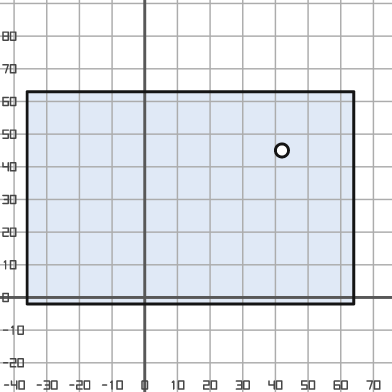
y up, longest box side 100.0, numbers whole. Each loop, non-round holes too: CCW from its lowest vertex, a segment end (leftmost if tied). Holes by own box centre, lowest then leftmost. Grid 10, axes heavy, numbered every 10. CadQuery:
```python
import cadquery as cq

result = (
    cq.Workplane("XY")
    .moveTo(-36.0, -2.0)
    .lineTo(64.0, -2.0)
    .lineTo(64.0, 63.0)
    .lineTo(-36.0, 63.0)
    .close()
    .moveTo(42.0, 45.0)
    .circle(2.0)
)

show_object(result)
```